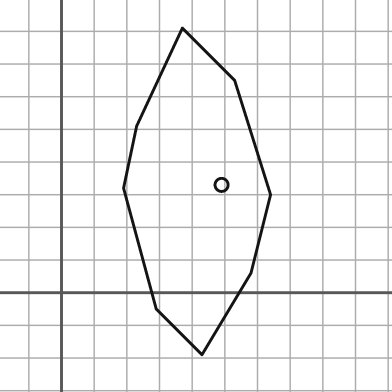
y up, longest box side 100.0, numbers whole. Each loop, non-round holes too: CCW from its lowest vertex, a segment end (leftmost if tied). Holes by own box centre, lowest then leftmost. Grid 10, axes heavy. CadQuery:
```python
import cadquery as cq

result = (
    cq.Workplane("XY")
    .moveTo(43.0, -19.0)
    .lineTo(58.0, 6.0)
    .lineTo(64.0, 30.0)
    .lineTo(53.0, 65.0)
    .lineTo(37.0, 81.0)
    .lineTo(23.0, 51.0)
    .lineTo(19.0, 32.0)
    .lineTo(29.0, -5.0)
    .close()
    .moveTo(49.0, 33.0)
    .circle(2.0)
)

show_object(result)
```